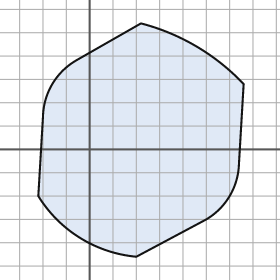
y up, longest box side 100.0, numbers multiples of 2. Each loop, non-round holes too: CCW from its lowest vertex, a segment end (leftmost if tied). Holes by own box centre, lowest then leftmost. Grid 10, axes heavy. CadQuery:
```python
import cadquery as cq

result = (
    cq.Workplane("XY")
    .moveTo(20.0, -46.0)
    .lineTo(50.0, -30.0)
    .threePointArc((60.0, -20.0), (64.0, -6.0))
    .lineTo(66.0, 28.0)
    .threePointArc((46.0, 44.0), (22.0, 54.0))
    .lineTo(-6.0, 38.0)
    .threePointArc((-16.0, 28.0), (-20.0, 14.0))
    .lineTo(-22.0, -20.0)
    .threePointArc((-4.0, -38.0), (20.0, -46.0))
    .close()
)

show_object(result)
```